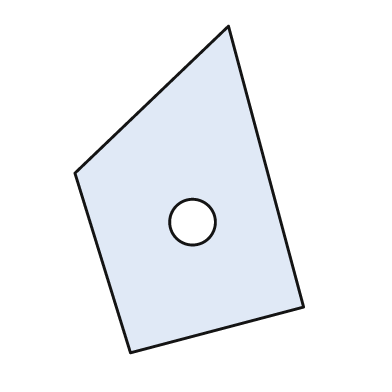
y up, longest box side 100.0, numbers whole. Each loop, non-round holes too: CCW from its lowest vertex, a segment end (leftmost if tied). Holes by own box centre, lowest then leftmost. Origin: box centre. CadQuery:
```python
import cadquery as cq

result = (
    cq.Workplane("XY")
    .moveTo(-18.0, -50.0)
    .lineTo(35.0, -36.0)
    .lineTo(12.0, 50.0)
    .lineTo(-35.0, 5.0)
    .close()
    .moveTo(1.0, -10.0)
    .circle(7.0)
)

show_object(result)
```